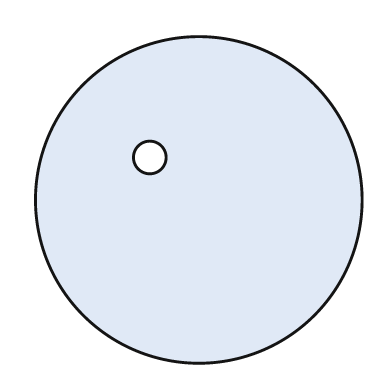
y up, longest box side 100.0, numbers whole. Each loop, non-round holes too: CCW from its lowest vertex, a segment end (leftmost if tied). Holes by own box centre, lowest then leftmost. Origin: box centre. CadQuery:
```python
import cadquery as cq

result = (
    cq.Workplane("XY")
    .moveTo(0.0, 0.0)
    .circle(50.0)
    .moveTo(-15.0, 13.0)
    .circle(5.0)
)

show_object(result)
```